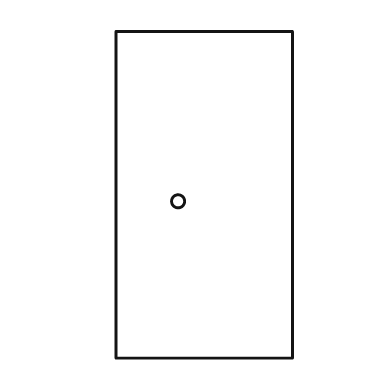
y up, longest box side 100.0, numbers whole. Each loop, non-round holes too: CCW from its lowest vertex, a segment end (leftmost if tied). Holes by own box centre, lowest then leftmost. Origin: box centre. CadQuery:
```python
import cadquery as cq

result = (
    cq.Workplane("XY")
    .moveTo(-27.0, -50.0)
    .lineTo(27.0, -50.0)
    .lineTo(27.0, 50.0)
    .lineTo(-27.0, 50.0)
    .close()
    .moveTo(-8.0, -2.0)
    .circle(2.0)
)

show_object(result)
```